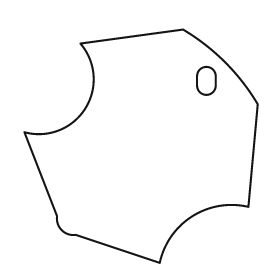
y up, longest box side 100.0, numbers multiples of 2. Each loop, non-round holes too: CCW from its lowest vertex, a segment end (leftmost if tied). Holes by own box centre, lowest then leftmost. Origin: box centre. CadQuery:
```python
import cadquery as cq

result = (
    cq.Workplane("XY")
    .moveTo(8.0, -50.0)
    .threePointArc((22.0, -30.0), (46.0, -26.0))
    .lineTo(50.0, 18.0)
    .threePointArc((36.0, 36.0), (18.0, 50.0))
    .lineTo(-26.0, 44.0)
    .threePointArc((-24.0, 16.0), (-50.0, 6.0))
    .lineTo(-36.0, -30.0)
    .threePointArc((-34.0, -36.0), (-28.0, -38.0))
    .close()
    .moveTo(24.0, 26.0)
    .threePointArc((28.0, 22.0), (32.0, 26.0))
    .lineTo(32.0, 30.0)
    .threePointArc((28.0, 34.0), (24.0, 30.0))
    .close()
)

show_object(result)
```